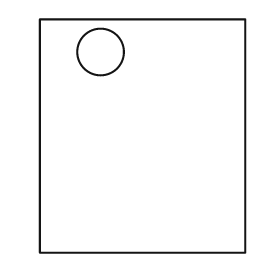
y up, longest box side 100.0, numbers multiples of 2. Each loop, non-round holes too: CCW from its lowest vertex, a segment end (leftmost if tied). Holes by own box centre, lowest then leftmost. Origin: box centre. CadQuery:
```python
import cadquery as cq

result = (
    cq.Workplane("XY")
    .moveTo(-44.0, -50.0)
    .lineTo(44.0, -50.0)
    .lineTo(44.0, 50.0)
    .lineTo(-44.0, 50.0)
    .close()
    .moveTo(-18.0, 36.0)
    .circle(10.0)
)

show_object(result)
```